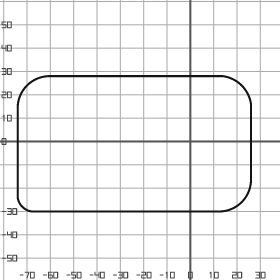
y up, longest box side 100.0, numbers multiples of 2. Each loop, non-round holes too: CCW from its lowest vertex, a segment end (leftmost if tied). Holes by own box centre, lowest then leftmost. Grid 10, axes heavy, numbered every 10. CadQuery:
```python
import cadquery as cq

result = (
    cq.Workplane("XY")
    .moveTo(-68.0, -30.0)
    .lineTo(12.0, -30.0)
    .threePointArc((22.0, -26.0), (26.0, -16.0))
    .lineTo(26.0, 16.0)
    .threePointArc((22.0, 24.0), (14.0, 28.0))
    .lineTo(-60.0, 28.0)
    .threePointArc((-70.0, 24.0), (-74.0, 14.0))
    .lineTo(-74.0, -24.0)
    .threePointArc((-72.0, -28.0), (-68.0, -30.0))
    .close()
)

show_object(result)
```